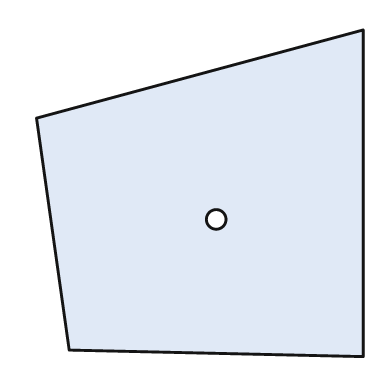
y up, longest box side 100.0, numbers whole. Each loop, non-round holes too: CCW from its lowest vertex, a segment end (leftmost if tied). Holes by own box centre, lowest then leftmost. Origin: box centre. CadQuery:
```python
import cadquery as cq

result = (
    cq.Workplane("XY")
    .moveTo(50.0, -50.0)
    .lineTo(50.0, 50.0)
    .lineTo(-50.0, 23.0)
    .lineTo(-40.0, -48.0)
    .close()
    .moveTo(5.0, -8.0)
    .circle(3.0)
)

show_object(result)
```